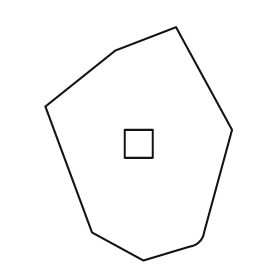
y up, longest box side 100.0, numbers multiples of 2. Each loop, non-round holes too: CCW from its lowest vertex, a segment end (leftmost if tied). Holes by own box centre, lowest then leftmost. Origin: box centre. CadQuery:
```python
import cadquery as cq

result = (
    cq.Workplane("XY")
    .moveTo(2.0, -50.0)
    .lineTo(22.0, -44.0)
    .threePointArc((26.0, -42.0), (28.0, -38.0))
    .lineTo(40.0, 6.0)
    .lineTo(16.0, 50.0)
    .lineTo(-10.0, 40.0)
    .lineTo(-40.0, 16.0)
    .lineTo(-20.0, -38.0)
    .close()
    .moveTo(-6.0, -6.0)
    .lineTo(6.0, -6.0)
    .lineTo(6.0, 6.0)
    .lineTo(-6.0, 6.0)
    .close()
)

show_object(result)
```